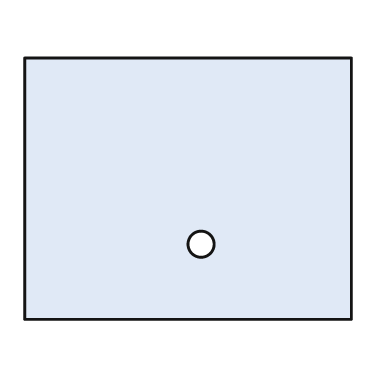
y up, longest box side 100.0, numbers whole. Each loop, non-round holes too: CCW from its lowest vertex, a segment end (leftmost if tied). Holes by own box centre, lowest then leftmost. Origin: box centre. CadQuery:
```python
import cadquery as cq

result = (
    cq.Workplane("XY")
    .moveTo(-50.0, -40.0)
    .lineTo(50.0, -40.0)
    .lineTo(50.0, 40.0)
    .lineTo(-50.0, 40.0)
    .close()
    .moveTo(4.0, -17.0)
    .circle(4.0)
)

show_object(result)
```